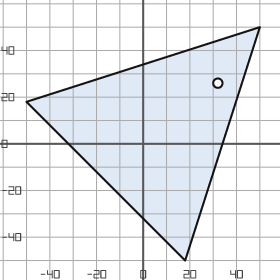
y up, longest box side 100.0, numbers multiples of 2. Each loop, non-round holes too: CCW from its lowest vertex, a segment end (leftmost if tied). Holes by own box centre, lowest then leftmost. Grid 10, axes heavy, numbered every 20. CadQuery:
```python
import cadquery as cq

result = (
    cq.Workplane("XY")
    .moveTo(18.0, -50.0)
    .lineTo(50.0, 50.0)
    .lineTo(-50.0, 18.0)
    .close()
    .moveTo(32.0, 26.0)
    .circle(2.0)
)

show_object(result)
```